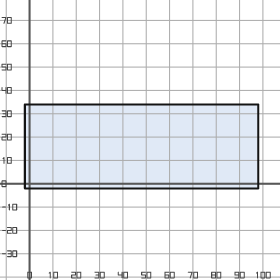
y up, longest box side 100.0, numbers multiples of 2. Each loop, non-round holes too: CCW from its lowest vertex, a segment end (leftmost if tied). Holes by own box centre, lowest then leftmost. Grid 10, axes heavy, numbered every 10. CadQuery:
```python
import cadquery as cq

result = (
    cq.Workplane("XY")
    .moveTo(-2.0, -2.0)
    .lineTo(98.0, -2.0)
    .lineTo(98.0, 34.0)
    .lineTo(-2.0, 34.0)
    .close()
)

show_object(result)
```